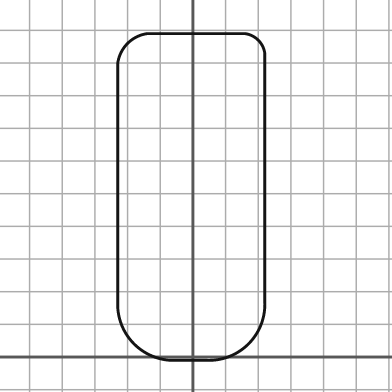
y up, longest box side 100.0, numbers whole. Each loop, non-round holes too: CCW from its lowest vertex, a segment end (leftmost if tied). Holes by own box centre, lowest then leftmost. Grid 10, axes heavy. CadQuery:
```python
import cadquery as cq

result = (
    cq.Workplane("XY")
    .moveTo(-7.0, -1.0)
    .lineTo(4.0, -1.0)
    .threePointArc((17.0, 4.0), (22.0, 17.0))
    .lineTo(22.0, 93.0)
    .threePointArc((20.0, 97.0), (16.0, 99.0))
    .lineTo(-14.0, 99.0)
    .threePointArc((-20.0, 96.0), (-23.0, 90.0))
    .lineTo(-23.0, 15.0)
    .threePointArc((-18.0, 4.0), (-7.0, -1.0))
    .close()
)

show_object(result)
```